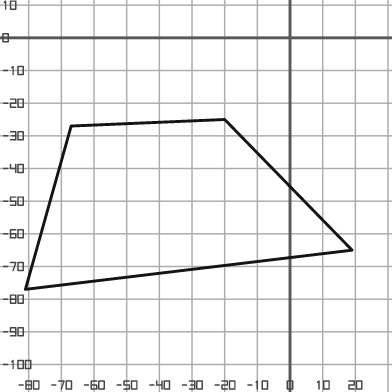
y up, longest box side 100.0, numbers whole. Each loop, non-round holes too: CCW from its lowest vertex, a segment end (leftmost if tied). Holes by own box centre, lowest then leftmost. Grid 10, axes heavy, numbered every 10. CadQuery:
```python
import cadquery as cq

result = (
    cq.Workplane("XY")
    .moveTo(-81.0, -77.0)
    .lineTo(19.0, -65.0)
    .lineTo(-20.0, -25.0)
    .lineTo(-67.0, -27.0)
    .close()
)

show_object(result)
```